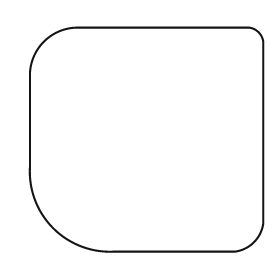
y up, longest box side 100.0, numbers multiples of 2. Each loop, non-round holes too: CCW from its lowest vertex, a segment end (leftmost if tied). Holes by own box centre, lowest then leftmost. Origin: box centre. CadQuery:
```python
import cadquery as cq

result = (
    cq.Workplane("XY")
    .moveTo(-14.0, -48.0)
    .lineTo(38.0, -48.0)
    .threePointArc((46.0, -44.0), (50.0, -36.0))
    .lineTo(50.0, 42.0)
    .threePointArc((48.0, 46.0), (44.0, 48.0))
    .lineTo(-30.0, 48.0)
    .threePointArc((-44.0, 42.0), (-50.0, 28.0))
    .lineTo(-50.0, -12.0)
    .threePointArc((-40.0, -38.0), (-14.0, -48.0))
    .close()
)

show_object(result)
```